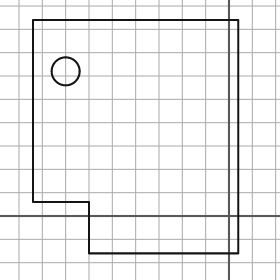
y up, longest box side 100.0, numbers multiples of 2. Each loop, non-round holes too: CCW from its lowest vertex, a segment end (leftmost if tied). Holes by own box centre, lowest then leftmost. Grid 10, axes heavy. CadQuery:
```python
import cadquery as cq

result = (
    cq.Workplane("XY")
    .moveTo(-60.0, -16.0)
    .lineTo(4.0, -16.0)
    .lineTo(4.0, 84.0)
    .lineTo(-84.0, 84.0)
    .lineTo(-84.0, 6.0)
    .lineTo(-60.0, 6.0)
    .close()
    .moveTo(-70.0, 62.0)
    .circle(6.0)
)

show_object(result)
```